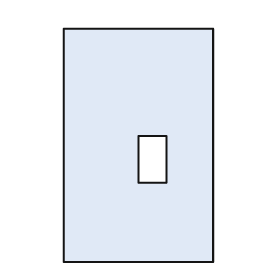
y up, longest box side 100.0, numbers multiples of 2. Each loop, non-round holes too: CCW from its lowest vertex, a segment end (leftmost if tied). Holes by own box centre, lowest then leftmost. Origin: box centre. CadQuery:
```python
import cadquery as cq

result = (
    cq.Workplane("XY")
    .moveTo(-32.0, -50.0)
    .lineTo(32.0, -50.0)
    .lineTo(32.0, 50.0)
    .lineTo(-32.0, 50.0)
    .close()
    .moveTo(0.0, -16.0)
    .lineTo(12.0, -16.0)
    .lineTo(12.0, 4.0)
    .lineTo(0.0, 4.0)
    .close()
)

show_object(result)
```